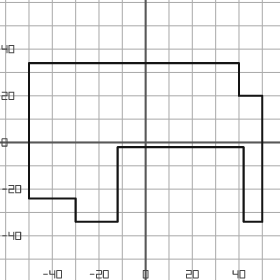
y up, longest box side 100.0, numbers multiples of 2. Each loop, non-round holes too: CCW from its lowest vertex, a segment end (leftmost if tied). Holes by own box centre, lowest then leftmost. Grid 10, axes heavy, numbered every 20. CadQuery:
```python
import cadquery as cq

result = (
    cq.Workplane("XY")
    .moveTo(-30.0, -34.0)
    .lineTo(-12.0, -34.0)
    .lineTo(-12.0, -2.0)
    .lineTo(42.0, -2.0)
    .lineTo(42.0, -34.0)
    .lineTo(50.0, -34.0)
    .lineTo(50.0, 20.0)
    .lineTo(40.0, 20.0)
    .lineTo(40.0, 34.0)
    .lineTo(-50.0, 34.0)
    .lineTo(-50.0, -24.0)
    .lineTo(-30.0, -24.0)
    .close()
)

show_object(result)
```